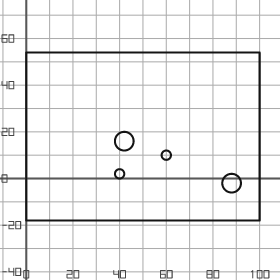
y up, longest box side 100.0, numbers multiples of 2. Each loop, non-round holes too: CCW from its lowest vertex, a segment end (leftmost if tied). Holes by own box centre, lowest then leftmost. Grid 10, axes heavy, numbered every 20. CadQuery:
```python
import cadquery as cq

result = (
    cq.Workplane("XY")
    .moveTo(0.0, -18.0)
    .lineTo(100.0, -18.0)
    .lineTo(100.0, 54.0)
    .lineTo(0.0, 54.0)
    .close()
    .moveTo(88.0, -2.0)
    .circle(4.0)
    .moveTo(40.0, 2.0)
    .circle(2.0)
    .moveTo(60.0, 10.0)
    .circle(2.0)
    .moveTo(42.0, 16.0)
    .circle(4.0)
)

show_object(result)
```